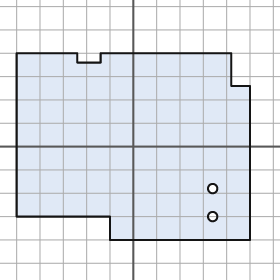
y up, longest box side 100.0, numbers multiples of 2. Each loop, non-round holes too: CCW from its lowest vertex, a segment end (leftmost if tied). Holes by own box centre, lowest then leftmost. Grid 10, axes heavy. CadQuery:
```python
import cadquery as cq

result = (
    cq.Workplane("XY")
    .moveTo(-10.0, -40.0)
    .lineTo(50.0, -40.0)
    .lineTo(50.0, 26.0)
    .lineTo(42.0, 26.0)
    .lineTo(42.0, 40.0)
    .lineTo(-14.0, 40.0)
    .lineTo(-14.0, 36.0)
    .lineTo(-24.0, 36.0)
    .lineTo(-24.0, 40.0)
    .lineTo(-50.0, 40.0)
    .lineTo(-50.0, -30.0)
    .lineTo(-10.0, -30.0)
    .close()
    .moveTo(34.0, -30.0)
    .circle(2.0)
    .moveTo(34.0, -18.0)
    .circle(2.0)
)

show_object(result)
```